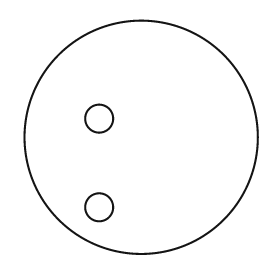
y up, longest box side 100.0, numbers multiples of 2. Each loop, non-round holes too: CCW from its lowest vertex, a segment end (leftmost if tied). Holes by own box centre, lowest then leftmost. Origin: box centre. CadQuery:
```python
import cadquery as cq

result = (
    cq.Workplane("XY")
    .moveTo(0.0, 0.0)
    .circle(50.0)
    .moveTo(-18.0, -30.0)
    .circle(6.0)
    .moveTo(-18.0, 8.0)
    .circle(6.0)
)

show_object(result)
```